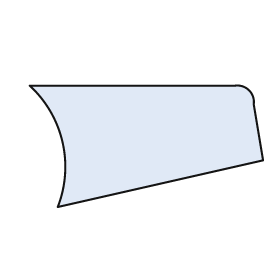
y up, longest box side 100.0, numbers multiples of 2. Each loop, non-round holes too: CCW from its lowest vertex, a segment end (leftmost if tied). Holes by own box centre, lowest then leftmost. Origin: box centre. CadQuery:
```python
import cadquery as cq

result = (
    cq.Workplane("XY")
    .moveTo(-38.0, -26.0)
    .lineTo(50.0, -6.0)
    .lineTo(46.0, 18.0)
    .threePointArc((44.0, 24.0), (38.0, 26.0))
    .lineTo(-50.0, 26.0)
    .threePointArc((-36.0, 2.0), (-38.0, -26.0))
    .close()
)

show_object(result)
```